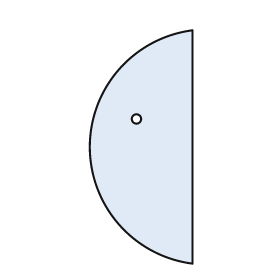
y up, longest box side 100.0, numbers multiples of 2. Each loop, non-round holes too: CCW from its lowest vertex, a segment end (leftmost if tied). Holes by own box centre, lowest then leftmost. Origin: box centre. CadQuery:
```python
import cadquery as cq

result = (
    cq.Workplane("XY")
    .moveTo(22.0, -50.0)
    .lineTo(22.0, 50.0)
    .threePointArc((-22.0, 0.0), (22.0, -50.0))
    .close()
    .moveTo(-2.0, 12.0)
    .circle(2.0)
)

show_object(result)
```